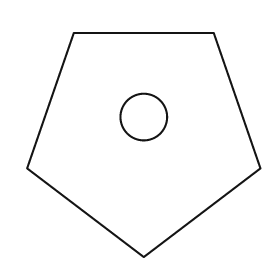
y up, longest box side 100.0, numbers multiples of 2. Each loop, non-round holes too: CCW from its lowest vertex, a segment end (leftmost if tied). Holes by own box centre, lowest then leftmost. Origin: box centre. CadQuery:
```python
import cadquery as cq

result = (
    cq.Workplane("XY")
    .moveTo(0.0, -48.0)
    .lineTo(50.0, -10.0)
    .lineTo(30.0, 48.0)
    .lineTo(-30.0, 48.0)
    .lineTo(-50.0, -10.0)
    .close()
    .moveTo(0.0, 12.0)
    .circle(10.0)
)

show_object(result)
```